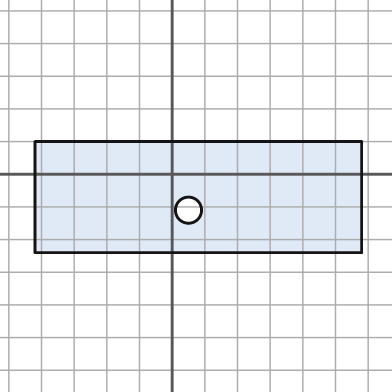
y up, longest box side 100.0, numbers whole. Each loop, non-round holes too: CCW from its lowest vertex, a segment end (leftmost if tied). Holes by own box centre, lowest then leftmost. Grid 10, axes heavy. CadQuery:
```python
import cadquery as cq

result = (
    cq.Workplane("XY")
    .moveTo(-42.0, -24.0)
    .lineTo(58.0, -24.0)
    .lineTo(58.0, 10.0)
    .lineTo(-42.0, 10.0)
    .close()
    .moveTo(5.0, -11.0)
    .circle(4.0)
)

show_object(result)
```